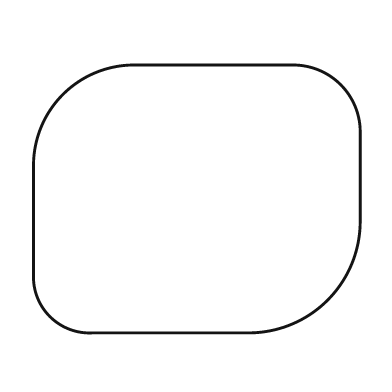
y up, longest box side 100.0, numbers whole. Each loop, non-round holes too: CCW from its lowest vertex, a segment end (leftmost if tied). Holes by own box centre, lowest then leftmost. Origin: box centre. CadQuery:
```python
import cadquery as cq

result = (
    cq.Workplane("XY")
    .moveTo(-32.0, -41.0)
    .lineTo(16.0, -41.0)
    .threePointArc((40.0, -31.0), (50.0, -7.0))
    .lineTo(50.0, 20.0)
    .threePointArc((44.0, 35.0), (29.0, 41.0))
    .lineTo(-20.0, 41.0)
    .threePointArc((-41.0, 32.0), (-50.0, 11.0))
    .lineTo(-50.0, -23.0)
    .threePointArc((-45.0, -36.0), (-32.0, -41.0))
    .close()
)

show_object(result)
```